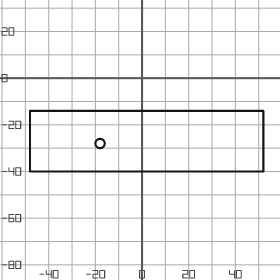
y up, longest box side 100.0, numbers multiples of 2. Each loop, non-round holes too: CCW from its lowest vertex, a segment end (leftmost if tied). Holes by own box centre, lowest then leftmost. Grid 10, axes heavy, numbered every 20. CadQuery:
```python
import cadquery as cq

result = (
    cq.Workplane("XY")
    .moveTo(-48.0, -40.0)
    .lineTo(52.0, -40.0)
    .lineTo(52.0, -14.0)
    .lineTo(-48.0, -14.0)
    .close()
    .moveTo(-18.0, -28.0)
    .circle(2.0)
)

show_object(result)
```